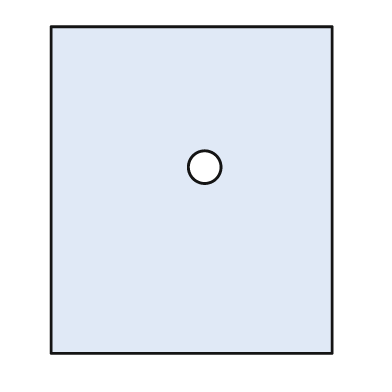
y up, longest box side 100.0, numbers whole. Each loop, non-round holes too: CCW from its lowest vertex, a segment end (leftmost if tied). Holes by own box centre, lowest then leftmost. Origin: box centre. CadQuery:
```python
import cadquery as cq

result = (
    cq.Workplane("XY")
    .moveTo(-43.0, -50.0)
    .lineTo(43.0, -50.0)
    .lineTo(43.0, 50.0)
    .lineTo(-43.0, 50.0)
    .close()
    .moveTo(4.0, 7.0)
    .circle(5.0)
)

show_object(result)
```